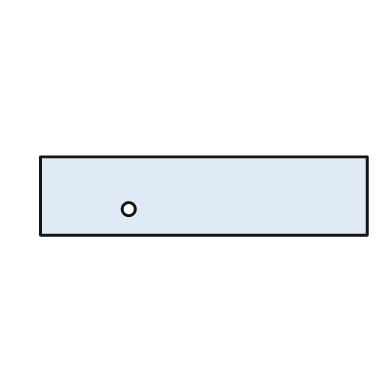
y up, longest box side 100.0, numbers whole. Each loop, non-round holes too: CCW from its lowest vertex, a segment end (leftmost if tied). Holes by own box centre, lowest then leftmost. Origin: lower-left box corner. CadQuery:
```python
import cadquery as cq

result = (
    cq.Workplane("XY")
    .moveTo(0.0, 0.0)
    .lineTo(100.0, 0.0)
    .lineTo(100.0, 24.0)
    .lineTo(0.0, 24.0)
    .close()
    .moveTo(27.0, 8.0)
    .circle(2.0)
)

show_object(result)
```